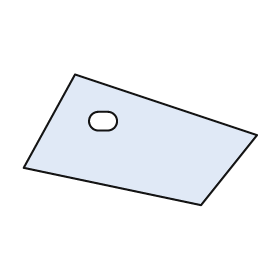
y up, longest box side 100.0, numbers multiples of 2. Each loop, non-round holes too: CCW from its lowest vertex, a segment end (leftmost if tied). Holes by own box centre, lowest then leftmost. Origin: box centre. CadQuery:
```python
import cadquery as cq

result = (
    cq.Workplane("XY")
    .moveTo(26.0, -28.0)
    .lineTo(50.0, 2.0)
    .lineTo(-28.0, 28.0)
    .lineTo(-50.0, -12.0)
    .close()
    .moveTo(-18.0, 4.0)
    .lineTo(-14.0, 4.0)
    .threePointArc((-10.0, 8.0), (-14.0, 12.0))
    .lineTo(-18.0, 12.0)
    .threePointArc((-22.0, 8.0), (-18.0, 4.0))
    .close()
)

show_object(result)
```